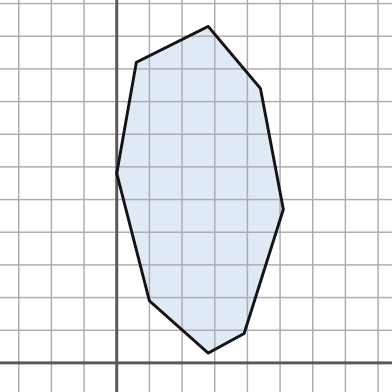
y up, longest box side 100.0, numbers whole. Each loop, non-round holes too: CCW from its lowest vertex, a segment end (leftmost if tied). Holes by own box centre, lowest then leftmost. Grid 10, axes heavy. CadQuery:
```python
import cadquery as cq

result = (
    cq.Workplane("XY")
    .moveTo(28.0, 3.0)
    .lineTo(39.0, 9.0)
    .lineTo(51.0, 47.0)
    .lineTo(44.0, 84.0)
    .lineTo(28.0, 103.0)
    .lineTo(6.0, 92.0)
    .lineTo(0.0, 58.0)
    .lineTo(10.0, 19.0)
    .close()
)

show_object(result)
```